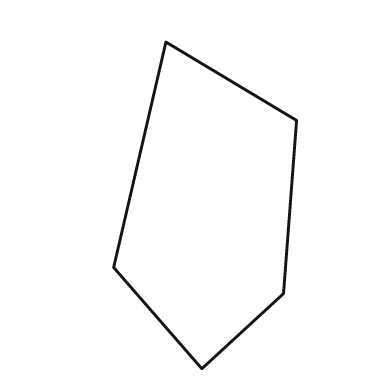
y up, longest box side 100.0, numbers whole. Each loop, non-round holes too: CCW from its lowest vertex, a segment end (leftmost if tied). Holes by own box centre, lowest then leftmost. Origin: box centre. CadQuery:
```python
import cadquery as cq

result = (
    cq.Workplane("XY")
    .moveTo(-1.0, -50.0)
    .lineTo(24.0, -27.0)
    .lineTo(28.0, 26.0)
    .lineTo(-12.0, 50.0)
    .lineTo(-28.0, -19.0)
    .close()
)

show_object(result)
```